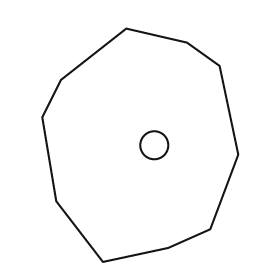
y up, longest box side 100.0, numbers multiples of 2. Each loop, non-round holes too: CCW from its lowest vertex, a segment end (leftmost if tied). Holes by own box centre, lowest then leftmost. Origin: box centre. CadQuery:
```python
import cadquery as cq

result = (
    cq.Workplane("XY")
    .moveTo(-16.0, -50.0)
    .lineTo(12.0, -44.0)
    .lineTo(30.0, -36.0)
    .lineTo(42.0, -4.0)
    .lineTo(34.0, 34.0)
    .lineTo(20.0, 44.0)
    .lineTo(-6.0, 50.0)
    .lineTo(-34.0, 28.0)
    .lineTo(-42.0, 12.0)
    .lineTo(-36.0, -24.0)
    .close()
    .moveTo(6.0, 0.0)
    .circle(6.0)
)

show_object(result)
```